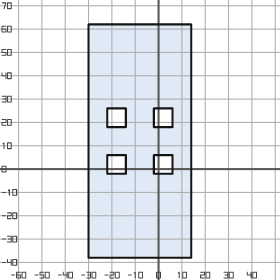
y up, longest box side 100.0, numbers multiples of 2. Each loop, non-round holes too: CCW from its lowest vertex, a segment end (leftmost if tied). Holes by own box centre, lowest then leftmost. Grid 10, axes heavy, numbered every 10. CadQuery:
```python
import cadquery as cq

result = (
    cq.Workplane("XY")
    .moveTo(-30.0, -38.0)
    .lineTo(14.0, -38.0)
    .lineTo(14.0, 62.0)
    .lineTo(-30.0, 62.0)
    .close()
    .moveTo(-22.0, -2.0)
    .lineTo(-14.0, -2.0)
    .lineTo(-14.0, 6.0)
    .lineTo(-22.0, 6.0)
    .close()
    .moveTo(-2.0, -2.0)
    .lineTo(6.0, -2.0)
    .lineTo(6.0, 6.0)
    .lineTo(-2.0, 6.0)
    .close()
    .moveTo(-22.0, 18.0)
    .lineTo(-14.0, 18.0)
    .lineTo(-14.0, 26.0)
    .lineTo(-22.0, 26.0)
    .close()
    .moveTo(-2.0, 18.0)
    .lineTo(6.0, 18.0)
    .lineTo(6.0, 26.0)
    .lineTo(-2.0, 26.0)
    .close()
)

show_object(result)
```